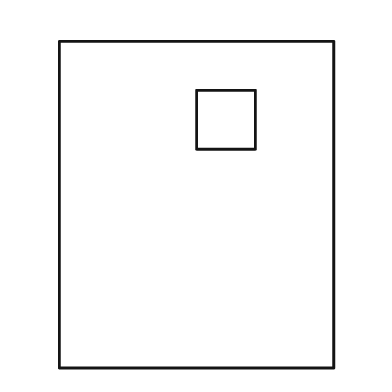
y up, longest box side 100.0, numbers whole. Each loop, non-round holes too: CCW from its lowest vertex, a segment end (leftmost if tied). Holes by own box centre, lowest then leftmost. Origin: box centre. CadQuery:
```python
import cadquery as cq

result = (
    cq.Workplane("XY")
    .moveTo(-42.0, -50.0)
    .lineTo(42.0, -50.0)
    .lineTo(42.0, 50.0)
    .lineTo(-42.0, 50.0)
    .close()
    .moveTo(0.0, 17.0)
    .lineTo(18.0, 17.0)
    .lineTo(18.0, 35.0)
    .lineTo(0.0, 35.0)
    .close()
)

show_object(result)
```